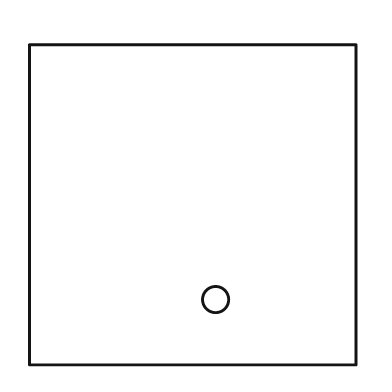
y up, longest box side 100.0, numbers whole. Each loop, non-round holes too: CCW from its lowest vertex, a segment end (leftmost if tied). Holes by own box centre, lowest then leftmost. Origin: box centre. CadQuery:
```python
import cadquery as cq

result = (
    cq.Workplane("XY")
    .moveTo(-50.0, -49.0)
    .lineTo(50.0, -49.0)
    .lineTo(50.0, 49.0)
    .lineTo(-50.0, 49.0)
    .close()
    .moveTo(7.0, -29.0)
    .circle(4.0)
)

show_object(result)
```